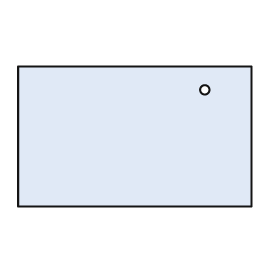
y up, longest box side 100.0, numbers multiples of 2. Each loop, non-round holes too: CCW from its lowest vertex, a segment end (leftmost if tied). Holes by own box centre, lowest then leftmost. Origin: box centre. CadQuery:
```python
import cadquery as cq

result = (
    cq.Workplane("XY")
    .moveTo(-50.0, -30.0)
    .lineTo(50.0, -30.0)
    .lineTo(50.0, 30.0)
    .lineTo(-50.0, 30.0)
    .close()
    .moveTo(30.0, 20.0)
    .circle(2.0)
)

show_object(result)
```